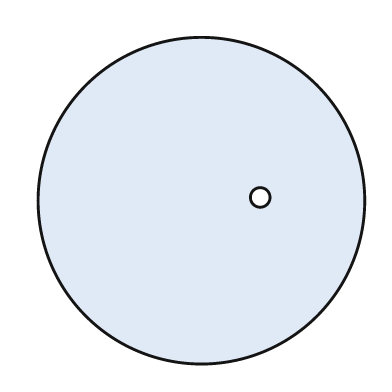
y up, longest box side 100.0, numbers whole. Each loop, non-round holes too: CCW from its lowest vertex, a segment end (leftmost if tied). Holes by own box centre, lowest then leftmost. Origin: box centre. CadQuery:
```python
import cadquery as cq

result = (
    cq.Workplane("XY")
    .moveTo(0.0, 0.0)
    .circle(50.0)
    .moveTo(18.0, 1.0)
    .circle(3.0)
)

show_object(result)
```